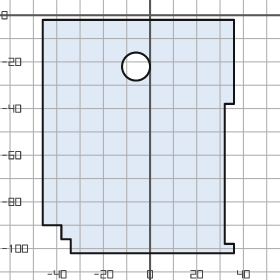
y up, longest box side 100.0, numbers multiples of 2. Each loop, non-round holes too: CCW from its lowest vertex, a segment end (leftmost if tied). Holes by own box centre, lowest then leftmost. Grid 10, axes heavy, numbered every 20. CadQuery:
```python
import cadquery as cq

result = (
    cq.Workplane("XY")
    .moveTo(-34.0, -102.0)
    .lineTo(36.0, -102.0)
    .lineTo(36.0, -98.0)
    .lineTo(32.0, -98.0)
    .lineTo(32.0, -38.0)
    .lineTo(36.0, -38.0)
    .lineTo(36.0, -2.0)
    .lineTo(-46.0, -2.0)
    .lineTo(-46.0, -90.0)
    .lineTo(-38.0, -90.0)
    .lineTo(-38.0, -96.0)
    .lineTo(-34.0, -96.0)
    .close()
    .moveTo(-6.0, -22.0)
    .circle(6.0)
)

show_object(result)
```